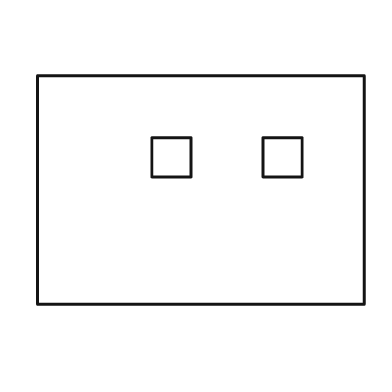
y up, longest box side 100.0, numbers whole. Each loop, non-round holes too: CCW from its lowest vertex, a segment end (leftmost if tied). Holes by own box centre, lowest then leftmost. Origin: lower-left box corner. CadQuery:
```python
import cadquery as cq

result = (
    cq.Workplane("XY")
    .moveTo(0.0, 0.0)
    .lineTo(100.0, 0.0)
    .lineTo(100.0, 70.0)
    .lineTo(0.0, 70.0)
    .close()
    .moveTo(35.0, 39.0)
    .lineTo(47.0, 39.0)
    .lineTo(47.0, 51.0)
    .lineTo(35.0, 51.0)
    .close()
    .moveTo(69.0, 39.0)
    .lineTo(81.0, 39.0)
    .lineTo(81.0, 51.0)
    .lineTo(69.0, 51.0)
    .close()
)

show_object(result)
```